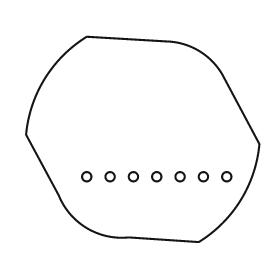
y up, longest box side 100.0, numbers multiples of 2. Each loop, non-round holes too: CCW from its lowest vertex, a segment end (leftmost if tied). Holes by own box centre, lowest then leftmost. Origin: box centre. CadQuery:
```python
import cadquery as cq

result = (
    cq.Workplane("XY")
    .moveTo(24.0, -44.0)
    .threePointArc((42.0, -26.0), (50.0, -2.0))
    .lineTo(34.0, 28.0)
    .threePointArc((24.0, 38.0), (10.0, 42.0))
    .lineTo(-24.0, 44.0)
    .threePointArc((-42.0, 26.0), (-50.0, 2.0))
    .lineTo(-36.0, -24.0)
    .threePointArc((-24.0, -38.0), (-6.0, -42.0))
    .close()
    .moveTo(-24.0, -16.0)
    .circle(2.0)
    .moveTo(-14.0, -16.0)
    .circle(2.0)
    .moveTo(-4.0, -16.0)
    .circle(2.0)
    .moveTo(6.0, -16.0)
    .circle(2.0)
    .moveTo(16.0, -16.0)
    .circle(2.0)
    .moveTo(26.0, -16.0)
    .circle(2.0)
    .moveTo(36.0, -16.0)
    .circle(2.0)
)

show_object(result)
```